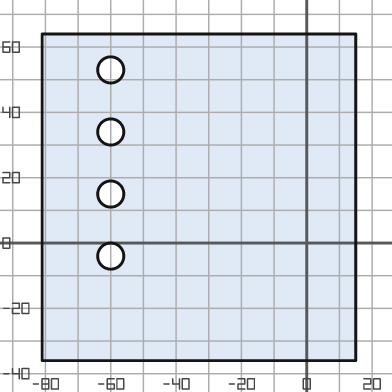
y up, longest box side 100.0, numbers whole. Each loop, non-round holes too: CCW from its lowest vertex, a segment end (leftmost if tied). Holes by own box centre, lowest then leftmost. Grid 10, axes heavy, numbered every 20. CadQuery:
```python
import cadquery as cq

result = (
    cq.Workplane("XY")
    .moveTo(-81.0, -36.0)
    .lineTo(15.0, -36.0)
    .lineTo(15.0, 64.0)
    .lineTo(-81.0, 64.0)
    .close()
    .moveTo(-60.0, -4.0)
    .circle(4.0)
    .moveTo(-60.0, 15.0)
    .circle(4.0)
    .moveTo(-60.0, 34.0)
    .circle(4.0)
    .moveTo(-60.0, 53.0)
    .circle(4.0)
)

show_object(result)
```